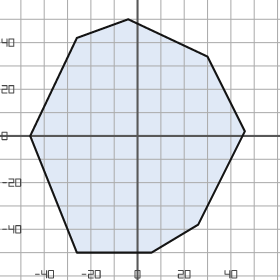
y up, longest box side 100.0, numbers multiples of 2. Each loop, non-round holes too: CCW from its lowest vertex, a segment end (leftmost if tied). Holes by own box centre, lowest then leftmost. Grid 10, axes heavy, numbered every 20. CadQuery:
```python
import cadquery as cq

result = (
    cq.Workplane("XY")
    .moveTo(-26.0, -50.0)
    .lineTo(6.0, -50.0)
    .lineTo(26.0, -38.0)
    .lineTo(46.0, 2.0)
    .lineTo(30.0, 34.0)
    .lineTo(-4.0, 50.0)
    .lineTo(-26.0, 42.0)
    .lineTo(-46.0, 0.0)
    .close()
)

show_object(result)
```